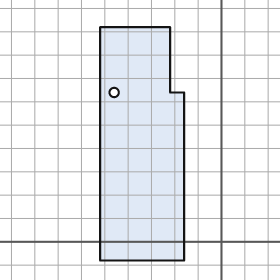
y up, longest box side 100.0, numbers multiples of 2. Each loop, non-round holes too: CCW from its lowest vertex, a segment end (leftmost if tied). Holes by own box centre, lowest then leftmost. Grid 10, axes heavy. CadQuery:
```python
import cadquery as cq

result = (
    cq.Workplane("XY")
    .moveTo(-52.0, -8.0)
    .lineTo(-16.0, -8.0)
    .lineTo(-16.0, 64.0)
    .lineTo(-22.0, 64.0)
    .lineTo(-22.0, 92.0)
    .lineTo(-52.0, 92.0)
    .close()
    .moveTo(-46.0, 64.0)
    .circle(2.0)
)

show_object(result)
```